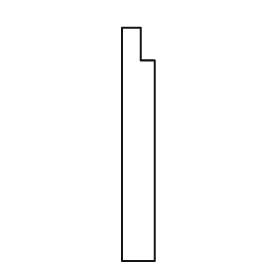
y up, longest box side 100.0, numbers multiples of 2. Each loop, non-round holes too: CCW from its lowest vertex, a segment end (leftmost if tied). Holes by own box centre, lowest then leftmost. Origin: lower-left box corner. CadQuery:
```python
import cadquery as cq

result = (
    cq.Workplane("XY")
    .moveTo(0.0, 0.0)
    .lineTo(14.0, 0.0)
    .lineTo(14.0, 86.0)
    .lineTo(8.0, 86.0)
    .lineTo(8.0, 100.0)
    .lineTo(0.0, 100.0)
    .close()
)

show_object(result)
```